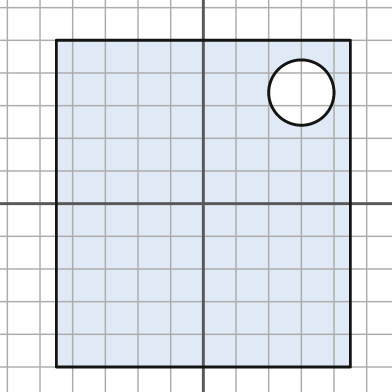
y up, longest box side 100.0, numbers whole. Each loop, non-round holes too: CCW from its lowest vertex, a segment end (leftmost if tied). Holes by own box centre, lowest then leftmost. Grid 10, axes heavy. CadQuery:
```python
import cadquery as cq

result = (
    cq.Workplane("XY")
    .moveTo(-45.0, -50.0)
    .lineTo(45.0, -50.0)
    .lineTo(45.0, 50.0)
    .lineTo(-45.0, 50.0)
    .close()
    .moveTo(30.0, 34.0)
    .circle(10.0)
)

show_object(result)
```